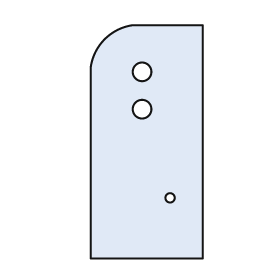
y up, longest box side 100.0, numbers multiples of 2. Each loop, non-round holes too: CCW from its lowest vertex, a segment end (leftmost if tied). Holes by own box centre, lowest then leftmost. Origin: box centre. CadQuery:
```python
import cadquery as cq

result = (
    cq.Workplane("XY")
    .moveTo(-24.0, -50.0)
    .lineTo(24.0, -50.0)
    .lineTo(24.0, 50.0)
    .lineTo(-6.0, 50.0)
    .threePointArc((-18.0, 44.0), (-24.0, 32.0))
    .close()
    .moveTo(10.0, -24.0)
    .circle(2.0)
    .moveTo(-2.0, 14.0)
    .circle(4.0)
    .moveTo(-2.0, 30.0)
    .circle(4.0)
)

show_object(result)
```